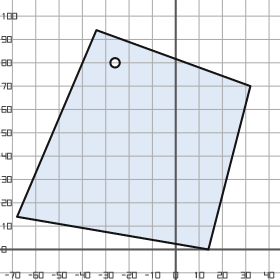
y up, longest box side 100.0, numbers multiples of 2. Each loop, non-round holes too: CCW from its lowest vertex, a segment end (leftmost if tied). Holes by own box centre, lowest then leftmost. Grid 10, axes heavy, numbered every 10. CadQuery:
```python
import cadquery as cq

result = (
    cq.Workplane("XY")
    .moveTo(14.0, 0.0)
    .lineTo(32.0, 70.0)
    .lineTo(-34.0, 94.0)
    .lineTo(-68.0, 14.0)
    .close()
    .moveTo(-26.0, 80.0)
    .circle(2.0)
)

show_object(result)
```